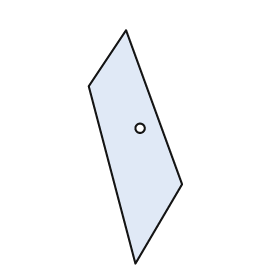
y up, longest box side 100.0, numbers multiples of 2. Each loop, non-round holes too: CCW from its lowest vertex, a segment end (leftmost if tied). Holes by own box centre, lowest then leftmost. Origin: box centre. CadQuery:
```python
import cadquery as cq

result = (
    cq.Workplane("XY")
    .moveTo(0.0, -50.0)
    .lineTo(20.0, -16.0)
    .lineTo(-4.0, 50.0)
    .lineTo(-20.0, 26.0)
    .close()
    .moveTo(2.0, 8.0)
    .circle(2.0)
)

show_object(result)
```